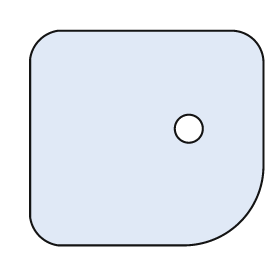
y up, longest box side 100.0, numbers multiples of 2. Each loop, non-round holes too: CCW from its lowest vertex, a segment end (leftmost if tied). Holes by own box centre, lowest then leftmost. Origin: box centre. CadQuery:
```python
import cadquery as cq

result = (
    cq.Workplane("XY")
    .moveTo(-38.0, -46.0)
    .lineTo(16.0, -46.0)
    .threePointArc((40.0, -36.0), (50.0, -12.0))
    .lineTo(50.0, 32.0)
    .threePointArc((46.0, 42.0), (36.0, 46.0))
    .lineTo(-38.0, 46.0)
    .threePointArc((-46.0, 42.0), (-50.0, 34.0))
    .lineTo(-50.0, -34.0)
    .threePointArc((-46.0, -42.0), (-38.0, -46.0))
    .close()
    .moveTo(18.0, 4.0)
    .circle(6.0)
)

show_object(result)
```